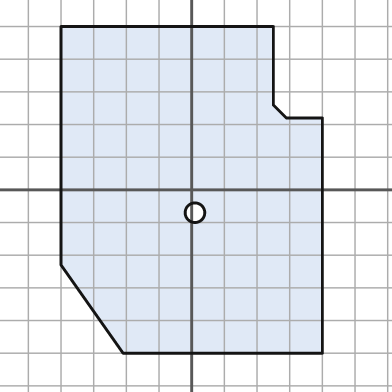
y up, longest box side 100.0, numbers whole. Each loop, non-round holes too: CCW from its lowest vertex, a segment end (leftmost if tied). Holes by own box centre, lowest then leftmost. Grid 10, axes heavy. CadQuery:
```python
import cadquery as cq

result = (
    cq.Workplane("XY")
    .moveTo(-21.0, -50.0)
    .lineTo(40.0, -50.0)
    .lineTo(40.0, 22.0)
    .lineTo(29.0, 22.0)
    .lineTo(25.0, 26.0)
    .lineTo(25.0, 50.0)
    .lineTo(-40.0, 50.0)
    .lineTo(-40.0, -23.0)
    .close()
    .moveTo(1.0, -7.0)
    .circle(3.0)
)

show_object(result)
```